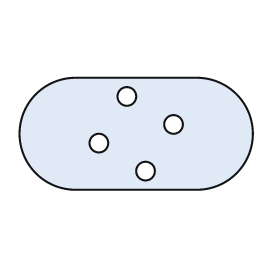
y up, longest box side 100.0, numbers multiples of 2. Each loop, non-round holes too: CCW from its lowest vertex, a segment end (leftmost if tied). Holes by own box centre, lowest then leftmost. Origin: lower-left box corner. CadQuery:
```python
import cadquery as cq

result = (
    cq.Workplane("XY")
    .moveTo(24.0, 0.0)
    .lineTo(76.0, 0.0)
    .threePointArc((100.0, 24.0), (76.0, 48.0))
    .lineTo(24.0, 48.0)
    .threePointArc((0.0, 24.0), (24.0, 0.0))
    .close()
    .moveTo(54.0, 8.0)
    .circle(4.0)
    .moveTo(34.0, 20.0)
    .circle(4.0)
    .moveTo(66.0, 28.0)
    .circle(4.0)
    .moveTo(46.0, 40.0)
    .circle(4.0)
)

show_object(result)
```